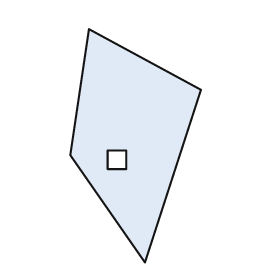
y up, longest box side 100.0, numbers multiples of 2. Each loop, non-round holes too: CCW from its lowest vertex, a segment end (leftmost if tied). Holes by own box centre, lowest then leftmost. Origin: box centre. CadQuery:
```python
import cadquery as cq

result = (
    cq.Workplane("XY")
    .moveTo(4.0, -50.0)
    .lineTo(28.0, 24.0)
    .lineTo(-20.0, 50.0)
    .lineTo(-28.0, -4.0)
    .close()
    .moveTo(-12.0, -10.0)
    .lineTo(-4.0, -10.0)
    .lineTo(-4.0, -2.0)
    .lineTo(-12.0, -2.0)
    .close()
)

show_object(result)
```